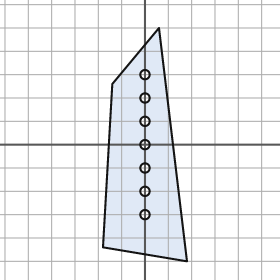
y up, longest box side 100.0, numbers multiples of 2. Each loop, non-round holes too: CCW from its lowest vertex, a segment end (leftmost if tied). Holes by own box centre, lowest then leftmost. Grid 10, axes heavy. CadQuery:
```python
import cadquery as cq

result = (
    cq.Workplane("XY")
    .moveTo(18.0, -50.0)
    .lineTo(6.0, 50.0)
    .lineTo(-14.0, 26.0)
    .lineTo(-18.0, -44.0)
    .close()
    .moveTo(0.0, -30.0)
    .circle(2.0)
    .moveTo(0.0, -20.0)
    .circle(2.0)
    .moveTo(0.0, -10.0)
    .circle(2.0)
    .moveTo(0.0, 0.0)
    .circle(2.0)
    .moveTo(0.0, 10.0)
    .circle(2.0)
    .moveTo(0.0, 20.0)
    .circle(2.0)
    .moveTo(0.0, 30.0)
    .circle(2.0)
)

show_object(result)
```